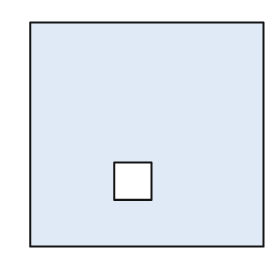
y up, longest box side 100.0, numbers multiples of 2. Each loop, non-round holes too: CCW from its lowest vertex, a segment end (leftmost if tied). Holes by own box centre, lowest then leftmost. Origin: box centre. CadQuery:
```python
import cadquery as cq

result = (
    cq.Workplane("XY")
    .moveTo(-50.0, -48.0)
    .lineTo(50.0, -48.0)
    .lineTo(50.0, 48.0)
    .lineTo(-50.0, 48.0)
    .close()
    .moveTo(-14.0, -28.0)
    .lineTo(2.0, -28.0)
    .lineTo(2.0, -12.0)
    .lineTo(-14.0, -12.0)
    .close()
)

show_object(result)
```